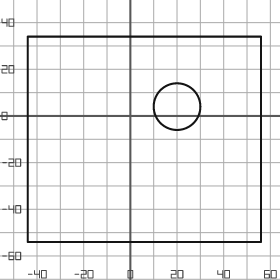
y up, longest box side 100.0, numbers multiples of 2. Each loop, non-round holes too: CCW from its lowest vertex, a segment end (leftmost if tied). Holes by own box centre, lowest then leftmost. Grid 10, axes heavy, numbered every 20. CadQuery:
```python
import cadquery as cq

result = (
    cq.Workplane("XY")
    .moveTo(-44.0, -54.0)
    .lineTo(56.0, -54.0)
    .lineTo(56.0, 34.0)
    .lineTo(-44.0, 34.0)
    .close()
    .moveTo(20.0, 4.0)
    .circle(10.0)
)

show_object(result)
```